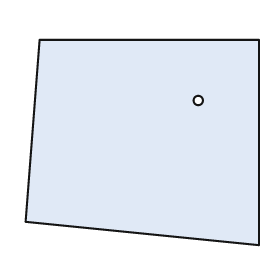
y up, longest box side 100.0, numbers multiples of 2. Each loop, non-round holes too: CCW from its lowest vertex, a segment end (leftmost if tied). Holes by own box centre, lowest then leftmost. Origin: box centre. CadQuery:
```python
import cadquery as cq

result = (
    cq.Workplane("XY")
    .moveTo(50.0, -44.0)
    .lineTo(50.0, 44.0)
    .lineTo(-44.0, 44.0)
    .lineTo(-50.0, -34.0)
    .close()
    .moveTo(24.0, 18.0)
    .circle(2.0)
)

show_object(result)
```